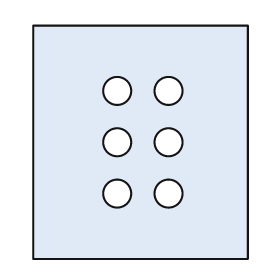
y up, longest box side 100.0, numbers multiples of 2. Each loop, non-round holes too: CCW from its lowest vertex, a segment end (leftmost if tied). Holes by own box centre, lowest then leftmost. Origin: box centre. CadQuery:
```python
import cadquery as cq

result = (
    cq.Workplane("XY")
    .moveTo(-46.0, -50.0)
    .lineTo(46.0, -50.0)
    .lineTo(46.0, 50.0)
    .lineTo(-46.0, 50.0)
    .close()
    .moveTo(-10.0, -22.0)
    .circle(6.0)
    .moveTo(12.0, -22.0)
    .circle(6.0)
    .moveTo(-10.0, 0.0)
    .circle(6.0)
    .moveTo(12.0, 0.0)
    .circle(6.0)
    .moveTo(-10.0, 22.0)
    .circle(6.0)
    .moveTo(12.0, 22.0)
    .circle(6.0)
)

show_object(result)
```